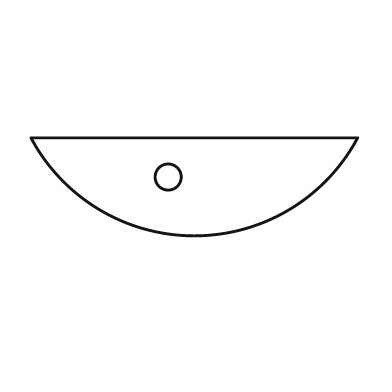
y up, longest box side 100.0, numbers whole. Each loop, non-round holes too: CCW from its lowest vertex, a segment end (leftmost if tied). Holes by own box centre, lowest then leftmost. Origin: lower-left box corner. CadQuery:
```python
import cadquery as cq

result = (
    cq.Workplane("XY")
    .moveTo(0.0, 30.0)
    .threePointArc((50.0, 0.0), (100.0, 30.0))
    .close()
    .moveTo(42.0, 18.0)
    .circle(4.0)
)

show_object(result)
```